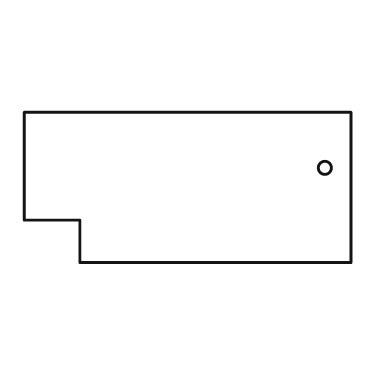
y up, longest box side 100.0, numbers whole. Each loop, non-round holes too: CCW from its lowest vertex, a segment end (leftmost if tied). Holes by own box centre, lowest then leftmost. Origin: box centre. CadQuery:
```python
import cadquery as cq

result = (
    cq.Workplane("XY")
    .moveTo(-33.0, -23.0)
    .lineTo(50.0, -23.0)
    .lineTo(50.0, 23.0)
    .lineTo(-50.0, 23.0)
    .lineTo(-50.0, -10.0)
    .lineTo(-33.0, -10.0)
    .close()
    .moveTo(42.0, 6.0)
    .circle(2.0)
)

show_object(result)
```